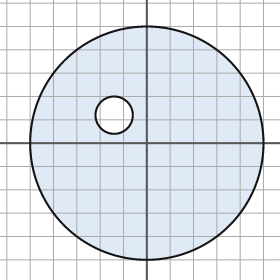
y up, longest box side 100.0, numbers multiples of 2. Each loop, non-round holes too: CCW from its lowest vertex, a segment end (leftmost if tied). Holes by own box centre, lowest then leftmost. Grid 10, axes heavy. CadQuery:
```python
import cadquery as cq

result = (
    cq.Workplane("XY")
    .moveTo(0.0, 0.0)
    .circle(50.0)
    .moveTo(-14.0, 12.0)
    .circle(8.0)
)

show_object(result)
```